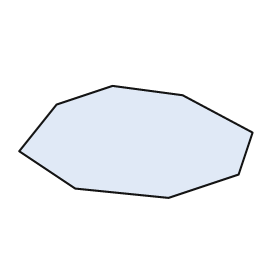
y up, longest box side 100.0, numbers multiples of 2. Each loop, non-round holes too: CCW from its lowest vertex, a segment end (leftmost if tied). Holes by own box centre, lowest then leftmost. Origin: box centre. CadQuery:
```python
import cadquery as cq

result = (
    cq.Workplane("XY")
    .moveTo(14.0, -24.0)
    .lineTo(44.0, -14.0)
    .lineTo(50.0, 4.0)
    .lineTo(20.0, 20.0)
    .lineTo(-10.0, 24.0)
    .lineTo(-34.0, 16.0)
    .lineTo(-50.0, -4.0)
    .lineTo(-26.0, -20.0)
    .close()
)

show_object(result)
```